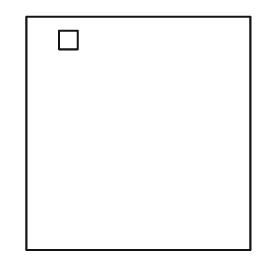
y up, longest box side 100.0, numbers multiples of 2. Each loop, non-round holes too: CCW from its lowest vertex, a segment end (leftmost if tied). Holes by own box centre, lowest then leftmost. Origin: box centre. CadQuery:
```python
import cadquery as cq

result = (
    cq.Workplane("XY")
    .moveTo(-48.0, -50.0)
    .lineTo(48.0, -50.0)
    .lineTo(48.0, 50.0)
    .lineTo(-48.0, 50.0)
    .close()
    .moveTo(-34.0, 36.0)
    .lineTo(-26.0, 36.0)
    .lineTo(-26.0, 44.0)
    .lineTo(-34.0, 44.0)
    .close()
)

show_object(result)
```